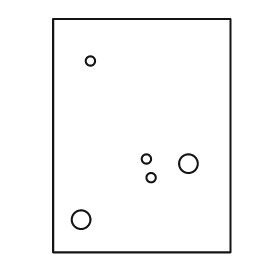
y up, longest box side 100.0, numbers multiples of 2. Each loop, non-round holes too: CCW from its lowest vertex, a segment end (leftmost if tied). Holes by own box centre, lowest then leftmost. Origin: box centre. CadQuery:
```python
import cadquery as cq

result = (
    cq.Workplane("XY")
    .moveTo(-38.0, -50.0)
    .lineTo(38.0, -50.0)
    .lineTo(38.0, 50.0)
    .lineTo(-38.0, 50.0)
    .close()
    .moveTo(-26.0, -36.0)
    .circle(4.0)
    .moveTo(4.0, -18.0)
    .circle(2.0)
    .moveTo(20.0, -12.0)
    .circle(4.0)
    .moveTo(2.0, -10.0)
    .circle(2.0)
    .moveTo(-22.0, 32.0)
    .circle(2.0)
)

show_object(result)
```